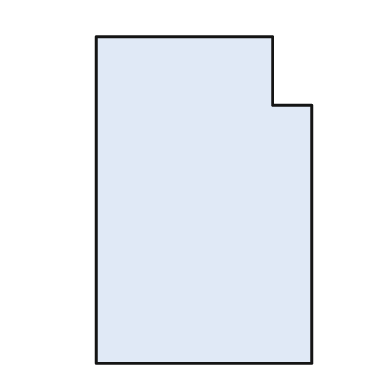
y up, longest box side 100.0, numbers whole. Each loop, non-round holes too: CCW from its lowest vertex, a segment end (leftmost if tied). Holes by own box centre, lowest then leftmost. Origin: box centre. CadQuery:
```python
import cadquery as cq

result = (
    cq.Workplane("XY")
    .moveTo(-33.0, -50.0)
    .lineTo(33.0, -50.0)
    .lineTo(33.0, 29.0)
    .lineTo(21.0, 29.0)
    .lineTo(21.0, 50.0)
    .lineTo(-33.0, 50.0)
    .close()
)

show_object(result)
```